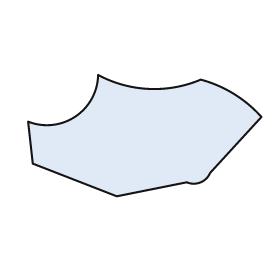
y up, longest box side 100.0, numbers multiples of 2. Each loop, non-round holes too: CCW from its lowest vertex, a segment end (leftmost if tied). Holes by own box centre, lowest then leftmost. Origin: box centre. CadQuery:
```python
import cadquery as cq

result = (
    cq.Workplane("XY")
    .moveTo(-12.0, -26.0)
    .lineTo(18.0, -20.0)
    .threePointArc((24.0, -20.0), (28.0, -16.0))
    .lineTo(50.0, 8.0)
    .threePointArc((38.0, 18.0), (24.0, 24.0))
    .threePointArc((2.0, 20.0), (-20.0, 26.0))
    .threePointArc((-30.0, 8.0), (-50.0, 6.0))
    .lineTo(-48.0, -12.0)
    .close()
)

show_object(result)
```